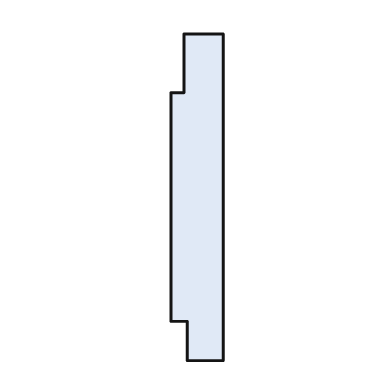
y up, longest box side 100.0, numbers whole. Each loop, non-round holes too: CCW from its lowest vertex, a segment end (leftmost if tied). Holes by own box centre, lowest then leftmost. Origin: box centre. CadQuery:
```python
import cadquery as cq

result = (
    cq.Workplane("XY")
    .moveTo(-3.0, -50.0)
    .lineTo(8.0, -50.0)
    .lineTo(8.0, 50.0)
    .lineTo(-4.0, 50.0)
    .lineTo(-4.0, 32.0)
    .lineTo(-8.0, 32.0)
    .lineTo(-8.0, -38.0)
    .lineTo(-3.0, -38.0)
    .close()
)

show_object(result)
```